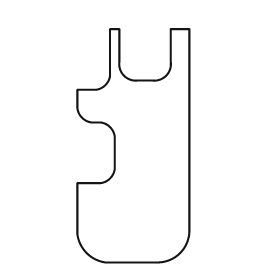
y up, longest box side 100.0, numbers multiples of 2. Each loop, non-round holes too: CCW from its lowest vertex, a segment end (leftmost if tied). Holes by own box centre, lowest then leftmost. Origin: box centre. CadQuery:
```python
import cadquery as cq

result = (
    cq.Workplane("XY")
    .moveTo(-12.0, -50.0)
    .lineTo(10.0, -50.0)
    .threePointArc((20.0, -46.0), (24.0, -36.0))
    .lineTo(24.0, 50.0)
    .lineTo(16.0, 50.0)
    .lineTo(16.0, 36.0)
    .threePointArc((14.0, 30.0), (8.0, 28.0))
    .lineTo(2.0, 28.0)
    .threePointArc((-4.0, 30.0), (-6.0, 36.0))
    .lineTo(-6.0, 50.0)
    .lineTo(-10.0, 50.0)
    .lineTo(-10.0, 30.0)
    .threePointArc((-12.0, 26.0), (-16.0, 24.0))
    .lineTo(-24.0, 24.0)
    .lineTo(-24.0, 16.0)
    .threePointArc((-22.0, 12.0), (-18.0, 10.0))
    .lineTo(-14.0, 10.0)
    .threePointArc((-10.0, 8.0), (-8.0, 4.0))
    .lineTo(-8.0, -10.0)
    .threePointArc((-10.0, -14.0), (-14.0, -16.0))
    .lineTo(-24.0, -16.0)
    .lineTo(-24.0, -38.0)
    .threePointArc((-20.0, -46.0), (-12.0, -50.0))
    .close()
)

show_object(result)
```